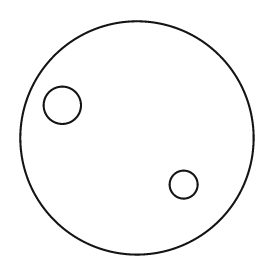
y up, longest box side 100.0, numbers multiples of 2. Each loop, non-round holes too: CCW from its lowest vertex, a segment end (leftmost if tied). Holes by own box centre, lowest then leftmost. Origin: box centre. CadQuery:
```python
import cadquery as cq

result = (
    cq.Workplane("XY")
    .moveTo(0.0, 0.0)
    .circle(50.0)
    .moveTo(20.0, -20.0)
    .circle(6.0)
    .moveTo(-32.0, 14.0)
    .circle(8.0)
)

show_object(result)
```